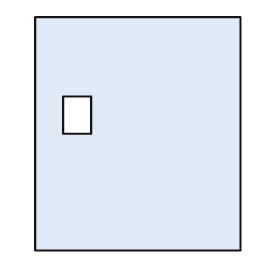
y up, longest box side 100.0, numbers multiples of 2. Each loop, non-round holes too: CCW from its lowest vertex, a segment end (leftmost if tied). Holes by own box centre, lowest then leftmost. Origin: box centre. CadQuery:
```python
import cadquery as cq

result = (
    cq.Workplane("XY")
    .moveTo(-44.0, -50.0)
    .lineTo(44.0, -50.0)
    .lineTo(44.0, 50.0)
    .lineTo(-44.0, 50.0)
    .close()
    .moveTo(-32.0, 0.0)
    .lineTo(-20.0, 0.0)
    .lineTo(-20.0, 16.0)
    .lineTo(-32.0, 16.0)
    .close()
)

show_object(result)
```